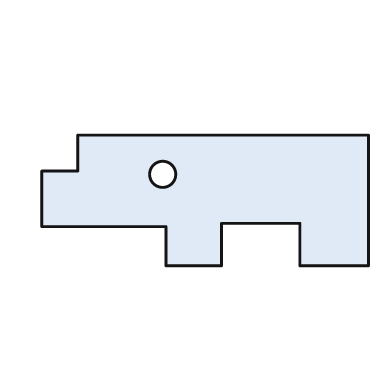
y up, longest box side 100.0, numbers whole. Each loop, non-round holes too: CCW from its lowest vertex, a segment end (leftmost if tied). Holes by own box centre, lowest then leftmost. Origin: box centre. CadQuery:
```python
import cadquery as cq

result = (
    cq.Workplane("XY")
    .moveTo(-12.0, -20.0)
    .lineTo(5.0, -20.0)
    .lineTo(5.0, -7.0)
    .lineTo(29.0, -7.0)
    .lineTo(29.0, -20.0)
    .lineTo(50.0, -20.0)
    .lineTo(50.0, 20.0)
    .lineTo(-39.0, 20.0)
    .lineTo(-39.0, 9.0)
    .lineTo(-50.0, 9.0)
    .lineTo(-50.0, -8.0)
    .lineTo(-12.0, -8.0)
    .close()
    .moveTo(-13.0, 8.0)
    .circle(4.0)
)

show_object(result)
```